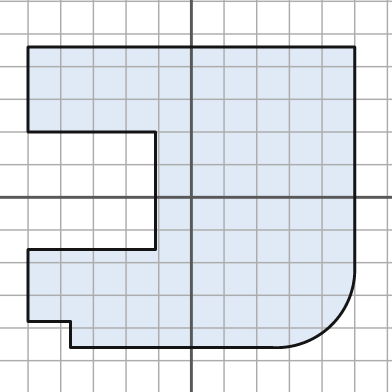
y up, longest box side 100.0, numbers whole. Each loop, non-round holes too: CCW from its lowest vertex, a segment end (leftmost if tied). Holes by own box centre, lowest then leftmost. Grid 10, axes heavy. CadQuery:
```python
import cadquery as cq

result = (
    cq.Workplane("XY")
    .moveTo(-37.0, -46.0)
    .lineTo(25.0, -46.0)
    .threePointArc((43.0, -39.0), (50.0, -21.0))
    .lineTo(50.0, 46.0)
    .lineTo(-50.0, 46.0)
    .lineTo(-50.0, 20.0)
    .lineTo(-11.0, 20.0)
    .lineTo(-11.0, -16.0)
    .lineTo(-50.0, -16.0)
    .lineTo(-50.0, -38.0)
    .lineTo(-37.0, -38.0)
    .close()
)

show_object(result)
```